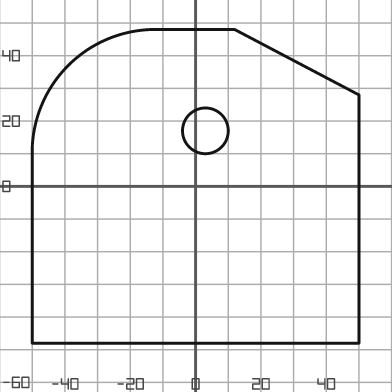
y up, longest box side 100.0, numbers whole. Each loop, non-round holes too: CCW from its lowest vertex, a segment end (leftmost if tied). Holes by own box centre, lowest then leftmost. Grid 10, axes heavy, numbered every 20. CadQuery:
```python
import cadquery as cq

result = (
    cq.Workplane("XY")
    .moveTo(-50.0, -48.0)
    .lineTo(50.0, -48.0)
    .lineTo(50.0, 28.0)
    .lineTo(12.0, 48.0)
    .lineTo(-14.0, 48.0)
    .threePointArc((-39.0, 37.0), (-50.0, 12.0))
    .close()
    .moveTo(3.0, 17.0)
    .circle(7.0)
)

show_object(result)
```